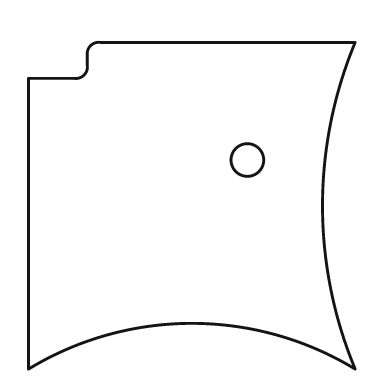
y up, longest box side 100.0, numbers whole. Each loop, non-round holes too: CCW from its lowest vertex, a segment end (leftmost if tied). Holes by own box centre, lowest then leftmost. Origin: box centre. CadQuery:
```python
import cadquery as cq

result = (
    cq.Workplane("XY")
    .moveTo(-50.0, -50.0)
    .threePointArc((0.0, -36.0), (50.0, -50.0))
    .threePointArc((40.0, 0.0), (50.0, 50.0))
    .lineTo(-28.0, 50.0)
    .threePointArc((-31.0, 49.0), (-32.0, 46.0))
    .lineTo(-32.0, 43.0)
    .threePointArc((-33.0, 40.0), (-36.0, 39.0))
    .lineTo(-50.0, 39.0)
    .close()
    .moveTo(17.0, 14.0)
    .circle(5.0)
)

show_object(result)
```